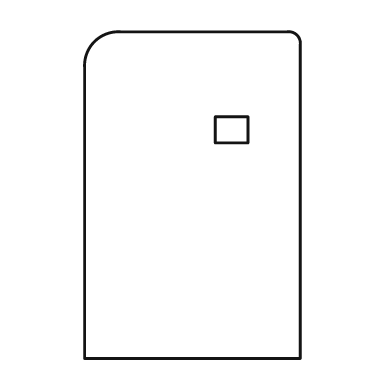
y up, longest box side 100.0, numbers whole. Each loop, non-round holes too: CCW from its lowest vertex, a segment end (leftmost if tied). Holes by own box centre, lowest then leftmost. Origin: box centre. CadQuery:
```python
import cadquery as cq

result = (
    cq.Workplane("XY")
    .moveTo(-33.0, -50.0)
    .lineTo(33.0, -50.0)
    .lineTo(33.0, 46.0)
    .threePointArc((32.0, 49.0), (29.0, 50.0))
    .lineTo(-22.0, 50.0)
    .threePointArc((-30.0, 47.0), (-33.0, 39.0))
    .close()
    .moveTo(7.0, 16.0)
    .lineTo(17.0, 16.0)
    .lineTo(17.0, 24.0)
    .lineTo(7.0, 24.0)
    .close()
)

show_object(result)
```